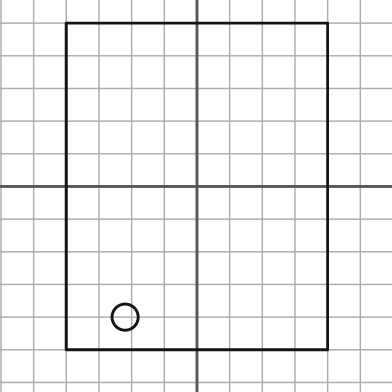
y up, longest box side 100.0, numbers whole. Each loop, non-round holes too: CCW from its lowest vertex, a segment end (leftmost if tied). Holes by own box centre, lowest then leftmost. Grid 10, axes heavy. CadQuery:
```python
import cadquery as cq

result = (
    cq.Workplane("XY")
    .moveTo(-40.0, -50.0)
    .lineTo(40.0, -50.0)
    .lineTo(40.0, 50.0)
    .lineTo(-40.0, 50.0)
    .close()
    .moveTo(-22.0, -40.0)
    .circle(4.0)
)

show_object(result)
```